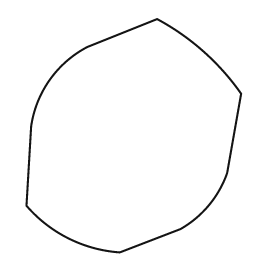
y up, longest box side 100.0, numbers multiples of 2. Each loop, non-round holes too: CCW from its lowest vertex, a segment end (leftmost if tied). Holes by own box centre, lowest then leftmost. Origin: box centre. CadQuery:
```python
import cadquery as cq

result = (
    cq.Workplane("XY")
    .moveTo(-6.0, -50.0)
    .lineTo(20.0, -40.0)
    .threePointArc((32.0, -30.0), (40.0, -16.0))
    .lineTo(46.0, 18.0)
    .threePointArc((30.0, 36.0), (10.0, 50.0))
    .lineTo(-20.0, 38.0)
    .threePointArc((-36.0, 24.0), (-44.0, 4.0))
    .lineTo(-46.0, -30.0)
    .threePointArc((-28.0, -44.0), (-6.0, -50.0))
    .close()
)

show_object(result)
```